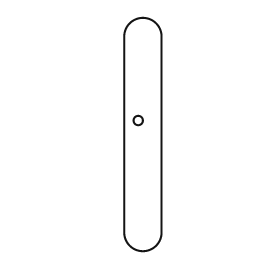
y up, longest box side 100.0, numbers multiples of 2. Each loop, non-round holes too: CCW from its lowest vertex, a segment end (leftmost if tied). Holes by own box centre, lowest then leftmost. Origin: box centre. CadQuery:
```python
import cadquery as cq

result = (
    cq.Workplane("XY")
    .moveTo(-8.0, -42.0)
    .threePointArc((0.0, -50.0), (8.0, -42.0))
    .lineTo(8.0, 42.0)
    .threePointArc((0.0, 50.0), (-8.0, 42.0))
    .close()
    .moveTo(-2.0, 6.0)
    .circle(2.0)
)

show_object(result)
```